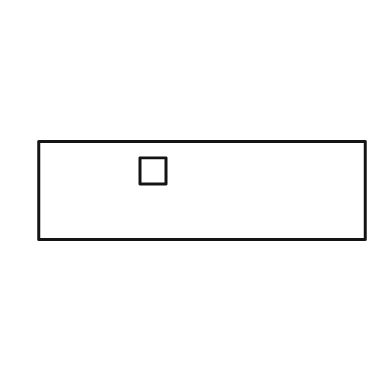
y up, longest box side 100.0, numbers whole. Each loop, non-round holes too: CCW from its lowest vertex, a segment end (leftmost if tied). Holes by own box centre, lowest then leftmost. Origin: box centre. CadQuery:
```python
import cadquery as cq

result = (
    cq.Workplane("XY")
    .moveTo(-50.0, -15.0)
    .lineTo(50.0, -15.0)
    .lineTo(50.0, 15.0)
    .lineTo(-50.0, 15.0)
    .close()
    .moveTo(-19.0, 2.0)
    .lineTo(-11.0, 2.0)
    .lineTo(-11.0, 10.0)
    .lineTo(-19.0, 10.0)
    .close()
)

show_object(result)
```